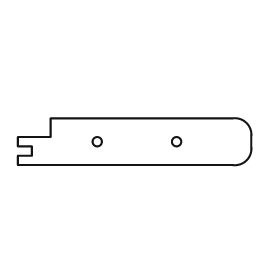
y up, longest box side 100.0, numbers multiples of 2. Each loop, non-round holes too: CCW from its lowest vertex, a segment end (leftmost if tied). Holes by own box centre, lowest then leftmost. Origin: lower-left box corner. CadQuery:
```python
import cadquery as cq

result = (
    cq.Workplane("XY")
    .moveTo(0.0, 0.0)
    .lineTo(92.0, 0.0)
    .threePointArc((98.0, 2.0), (100.0, 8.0))
    .lineTo(100.0, 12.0)
    .threePointArc((98.0, 18.0), (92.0, 20.0))
    .lineTo(14.0, 20.0)
    .lineTo(14.0, 12.0)
    .lineTo(0.0, 12.0)
    .lineTo(0.0, 8.0)
    .lineTo(6.0, 8.0)
    .lineTo(6.0, 4.0)
    .lineTo(0.0, 4.0)
    .close()
    .moveTo(34.0, 10.0)
    .circle(2.0)
    .moveTo(68.0, 10.0)
    .circle(2.0)
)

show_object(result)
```